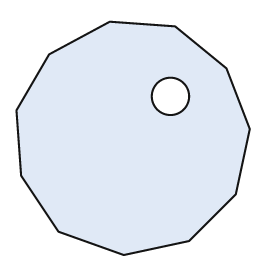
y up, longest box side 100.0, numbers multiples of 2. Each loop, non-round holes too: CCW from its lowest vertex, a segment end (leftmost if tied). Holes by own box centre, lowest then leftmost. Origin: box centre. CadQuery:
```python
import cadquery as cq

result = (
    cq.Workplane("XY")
    .moveTo(-4.0, -50.0)
    .lineTo(24.0, -44.0)
    .lineTo(44.0, -24.0)
    .lineTo(50.0, 4.0)
    .lineTo(40.0, 30.0)
    .lineTo(18.0, 48.0)
    .lineTo(-10.0, 50.0)
    .lineTo(-36.0, 36.0)
    .lineTo(-50.0, 12.0)
    .lineTo(-48.0, -16.0)
    .lineTo(-32.0, -40.0)
    .close()
    .moveTo(16.0, 18.0)
    .circle(8.0)
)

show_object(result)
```